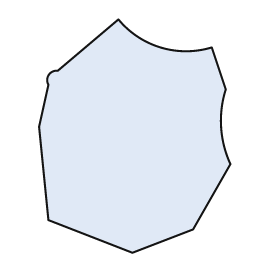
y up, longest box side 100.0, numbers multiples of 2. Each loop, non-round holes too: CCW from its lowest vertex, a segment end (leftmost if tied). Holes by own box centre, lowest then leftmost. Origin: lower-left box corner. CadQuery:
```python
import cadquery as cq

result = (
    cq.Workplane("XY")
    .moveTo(40.0, 0.0)
    .lineTo(66.0, 10.0)
    .lineTo(82.0, 38.0)
    .threePointArc((78.0, 54.0), (80.0, 70.0))
    .lineTo(74.0, 88.0)
    .threePointArc((52.0, 88.0), (34.0, 100.0))
    .lineTo(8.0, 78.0)
    .threePointArc((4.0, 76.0), (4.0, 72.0))
    .lineTo(0.0, 54.0)
    .lineTo(4.0, 14.0)
    .close()
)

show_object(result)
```